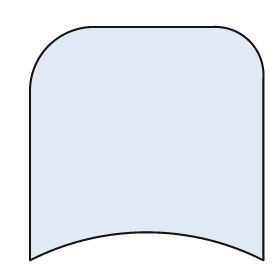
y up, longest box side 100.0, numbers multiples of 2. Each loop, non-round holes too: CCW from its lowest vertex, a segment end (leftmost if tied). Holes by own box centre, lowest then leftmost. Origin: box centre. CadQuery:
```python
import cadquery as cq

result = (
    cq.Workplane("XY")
    .moveTo(-50.0, -50.0)
    .threePointArc((0.0, -38.0), (50.0, -50.0))
    .lineTo(50.0, 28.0)
    .threePointArc((44.0, 44.0), (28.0, 50.0))
    .lineTo(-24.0, 50.0)
    .threePointArc((-42.0, 42.0), (-50.0, 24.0))
    .close()
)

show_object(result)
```